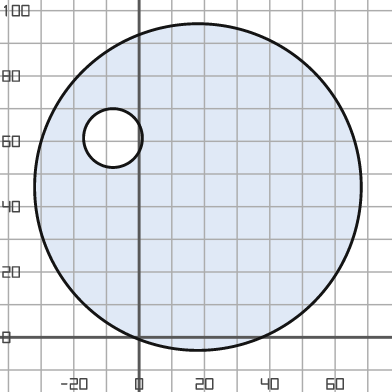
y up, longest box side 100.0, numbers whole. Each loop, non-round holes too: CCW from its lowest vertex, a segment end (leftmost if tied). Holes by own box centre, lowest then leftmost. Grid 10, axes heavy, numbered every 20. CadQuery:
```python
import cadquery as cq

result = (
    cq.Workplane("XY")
    .moveTo(18.0, 46.0)
    .circle(50.0)
    .moveTo(-8.0, 61.0)
    .circle(9.0)
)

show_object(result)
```